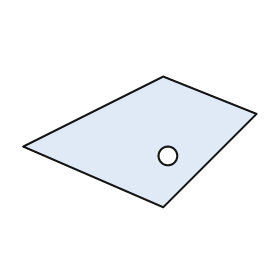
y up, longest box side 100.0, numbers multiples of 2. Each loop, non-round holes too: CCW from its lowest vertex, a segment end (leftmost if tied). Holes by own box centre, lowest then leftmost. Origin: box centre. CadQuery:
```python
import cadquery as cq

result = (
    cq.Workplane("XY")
    .moveTo(10.0, -28.0)
    .lineTo(50.0, 12.0)
    .lineTo(10.0, 28.0)
    .lineTo(-50.0, -2.0)
    .close()
    .moveTo(12.0, -6.0)
    .circle(4.0)
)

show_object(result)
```